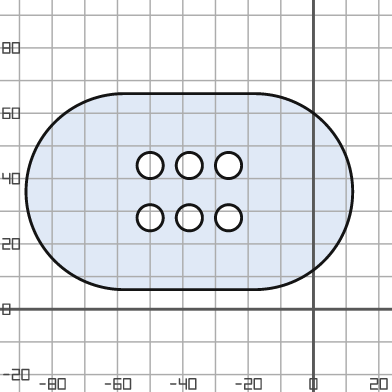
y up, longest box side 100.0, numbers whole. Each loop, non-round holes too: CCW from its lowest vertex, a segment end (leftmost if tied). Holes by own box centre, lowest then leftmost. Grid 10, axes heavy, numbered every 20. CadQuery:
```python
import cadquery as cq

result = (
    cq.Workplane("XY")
    .moveTo(-58.0, 6.0)
    .lineTo(-18.0, 6.0)
    .threePointArc((12.0, 36.0), (-18.0, 66.0))
    .lineTo(-58.0, 66.0)
    .threePointArc((-88.0, 36.0), (-58.0, 6.0))
    .close()
    .moveTo(-50.0, 28.0)
    .circle(4.0)
    .moveTo(-38.0, 28.0)
    .circle(4.0)
    .moveTo(-26.0, 28.0)
    .circle(4.0)
    .moveTo(-50.0, 44.0)
    .circle(4.0)
    .moveTo(-38.0, 44.0)
    .circle(4.0)
    .moveTo(-26.0, 44.0)
    .circle(4.0)
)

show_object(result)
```